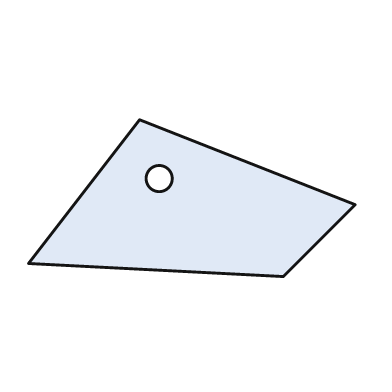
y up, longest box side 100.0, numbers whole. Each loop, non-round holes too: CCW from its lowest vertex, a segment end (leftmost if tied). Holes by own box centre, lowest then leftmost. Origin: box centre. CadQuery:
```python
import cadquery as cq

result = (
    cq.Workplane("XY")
    .moveTo(28.0, -24.0)
    .lineTo(50.0, -2.0)
    .lineTo(-16.0, 24.0)
    .lineTo(-50.0, -20.0)
    .close()
    .moveTo(-10.0, 6.0)
    .circle(4.0)
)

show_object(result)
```